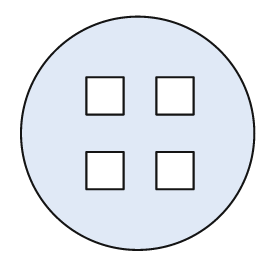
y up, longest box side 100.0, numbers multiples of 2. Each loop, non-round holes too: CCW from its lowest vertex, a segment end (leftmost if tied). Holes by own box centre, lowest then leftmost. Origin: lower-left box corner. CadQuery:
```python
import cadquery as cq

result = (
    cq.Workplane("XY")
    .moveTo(50.0, 50.0)
    .circle(50.0)
    .moveTo(28.0, 26.0)
    .lineTo(44.0, 26.0)
    .lineTo(44.0, 42.0)
    .lineTo(28.0, 42.0)
    .close()
    .moveTo(58.0, 26.0)
    .lineTo(74.0, 26.0)
    .lineTo(74.0, 42.0)
    .lineTo(58.0, 42.0)
    .close()
    .moveTo(28.0, 58.0)
    .lineTo(44.0, 58.0)
    .lineTo(44.0, 74.0)
    .lineTo(28.0, 74.0)
    .close()
    .moveTo(58.0, 58.0)
    .lineTo(74.0, 58.0)
    .lineTo(74.0, 74.0)
    .lineTo(58.0, 74.0)
    .close()
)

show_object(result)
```